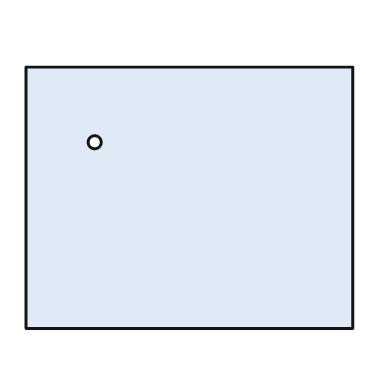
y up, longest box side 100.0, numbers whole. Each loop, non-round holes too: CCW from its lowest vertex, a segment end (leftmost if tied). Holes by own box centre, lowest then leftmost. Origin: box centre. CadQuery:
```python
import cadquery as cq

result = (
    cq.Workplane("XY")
    .moveTo(-50.0, -40.0)
    .lineTo(50.0, -40.0)
    .lineTo(50.0, 40.0)
    .lineTo(-50.0, 40.0)
    .close()
    .moveTo(-29.0, 17.0)
    .circle(2.0)
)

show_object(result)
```